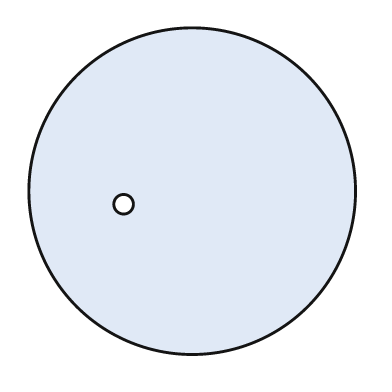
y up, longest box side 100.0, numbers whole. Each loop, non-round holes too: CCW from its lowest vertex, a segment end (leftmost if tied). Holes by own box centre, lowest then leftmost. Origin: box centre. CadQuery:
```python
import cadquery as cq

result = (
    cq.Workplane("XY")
    .moveTo(0.0, 0.0)
    .circle(50.0)
    .moveTo(-21.0, -4.0)
    .circle(3.0)
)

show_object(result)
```